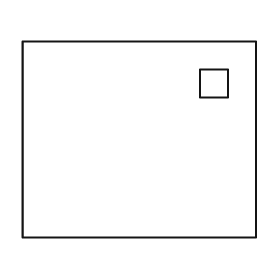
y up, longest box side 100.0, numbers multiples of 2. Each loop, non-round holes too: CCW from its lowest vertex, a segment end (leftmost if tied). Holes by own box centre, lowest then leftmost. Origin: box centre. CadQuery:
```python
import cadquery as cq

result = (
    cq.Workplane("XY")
    .moveTo(-50.0, -42.0)
    .lineTo(50.0, -42.0)
    .lineTo(50.0, 42.0)
    .lineTo(-50.0, 42.0)
    .close()
    .moveTo(26.0, 18.0)
    .lineTo(38.0, 18.0)
    .lineTo(38.0, 30.0)
    .lineTo(26.0, 30.0)
    .close()
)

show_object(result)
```